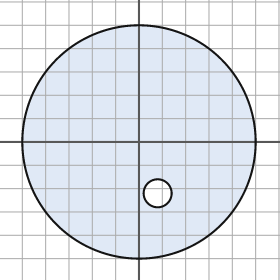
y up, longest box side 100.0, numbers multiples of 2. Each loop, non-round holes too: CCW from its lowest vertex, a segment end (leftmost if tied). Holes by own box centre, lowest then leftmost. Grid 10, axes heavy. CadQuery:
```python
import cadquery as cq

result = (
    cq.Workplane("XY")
    .moveTo(0.0, 0.0)
    .circle(50.0)
    .moveTo(8.0, -22.0)
    .circle(6.0)
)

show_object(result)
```